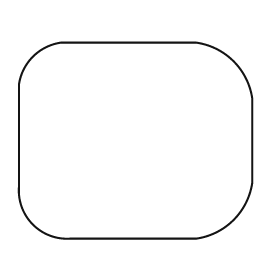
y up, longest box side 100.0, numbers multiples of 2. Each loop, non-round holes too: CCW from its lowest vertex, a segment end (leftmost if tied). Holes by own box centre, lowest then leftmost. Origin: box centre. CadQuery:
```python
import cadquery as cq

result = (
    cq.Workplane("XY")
    .moveTo(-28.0, -42.0)
    .lineTo(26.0, -42.0)
    .threePointArc((42.0, -34.0), (50.0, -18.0))
    .lineTo(50.0, 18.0)
    .threePointArc((42.0, 34.0), (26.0, 42.0))
    .lineTo(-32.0, 42.0)
    .threePointArc((-44.0, 36.0), (-50.0, 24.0))
    .lineTo(-50.0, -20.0)
    .threePointArc((-44.0, -36.0), (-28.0, -42.0))
    .close()
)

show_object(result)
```